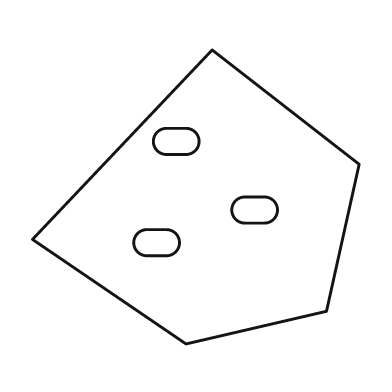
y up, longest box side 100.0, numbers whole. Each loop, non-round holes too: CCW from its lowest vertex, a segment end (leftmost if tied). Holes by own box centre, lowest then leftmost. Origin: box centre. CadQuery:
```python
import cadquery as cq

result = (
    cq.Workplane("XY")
    .moveTo(-3.0, -45.0)
    .lineTo(40.0, -35.0)
    .lineTo(50.0, 10.0)
    .lineTo(5.0, 45.0)
    .lineTo(-50.0, -13.0)
    .close()
    .moveTo(-15.0, -18.0)
    .lineTo(-9.0, -18.0)
    .threePointArc((-5.0, -14.0), (-9.0, -10.0))
    .lineTo(-15.0, -10.0)
    .threePointArc((-19.0, -14.0), (-15.0, -18.0))
    .close()
    .moveTo(15.0, -8.0)
    .lineTo(21.0, -8.0)
    .threePointArc((25.0, -4.0), (21.0, 0.0))
    .lineTo(15.0, 0.0)
    .threePointArc((11.0, -4.0), (15.0, -8.0))
    .close()
    .moveTo(-9.0, 13.0)
    .lineTo(-3.0, 13.0)
    .threePointArc((1.0, 17.0), (-3.0, 21.0))
    .lineTo(-9.0, 21.0)
    .threePointArc((-13.0, 17.0), (-9.0, 13.0))
    .close()
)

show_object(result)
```